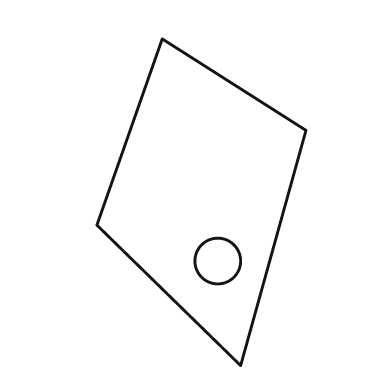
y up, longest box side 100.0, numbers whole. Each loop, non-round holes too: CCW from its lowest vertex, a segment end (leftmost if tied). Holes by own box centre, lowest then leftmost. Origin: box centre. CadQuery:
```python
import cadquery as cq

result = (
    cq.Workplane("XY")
    .moveTo(12.0, -50.0)
    .lineTo(32.0, 22.0)
    .lineTo(-12.0, 50.0)
    .lineTo(-32.0, -7.0)
    .close()
    .moveTo(5.0, -18.0)
    .circle(7.0)
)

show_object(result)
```